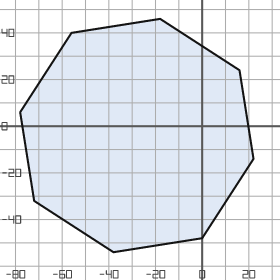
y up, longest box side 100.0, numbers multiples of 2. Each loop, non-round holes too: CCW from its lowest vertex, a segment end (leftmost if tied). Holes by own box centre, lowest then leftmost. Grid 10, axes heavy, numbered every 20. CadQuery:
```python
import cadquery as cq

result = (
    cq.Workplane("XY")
    .moveTo(-38.0, -54.0)
    .lineTo(0.0, -48.0)
    .lineTo(22.0, -14.0)
    .lineTo(16.0, 24.0)
    .lineTo(-18.0, 46.0)
    .lineTo(-56.0, 40.0)
    .lineTo(-78.0, 6.0)
    .lineTo(-72.0, -32.0)
    .close()
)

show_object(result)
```